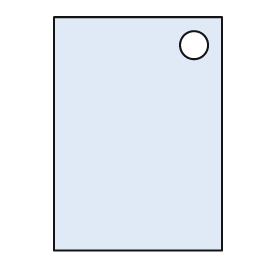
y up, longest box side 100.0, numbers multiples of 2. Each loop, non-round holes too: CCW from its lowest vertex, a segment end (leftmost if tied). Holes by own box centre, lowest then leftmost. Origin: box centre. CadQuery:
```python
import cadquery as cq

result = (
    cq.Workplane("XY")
    .moveTo(-36.0, -50.0)
    .lineTo(36.0, -50.0)
    .lineTo(36.0, 50.0)
    .lineTo(-36.0, 50.0)
    .close()
    .moveTo(24.0, 38.0)
    .circle(6.0)
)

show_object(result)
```